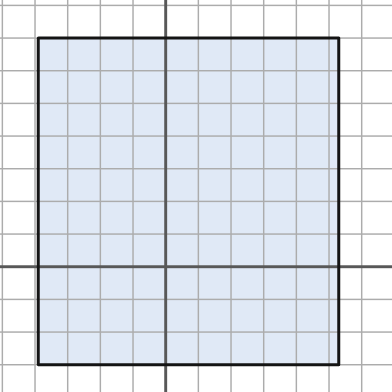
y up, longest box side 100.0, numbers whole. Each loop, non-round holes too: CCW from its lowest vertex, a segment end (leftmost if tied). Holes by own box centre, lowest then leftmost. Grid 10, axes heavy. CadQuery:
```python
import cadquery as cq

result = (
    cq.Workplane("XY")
    .moveTo(-39.0, -30.0)
    .lineTo(53.0, -30.0)
    .lineTo(53.0, 70.0)
    .lineTo(-39.0, 70.0)
    .close()
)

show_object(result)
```